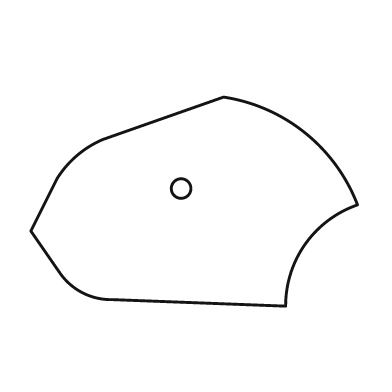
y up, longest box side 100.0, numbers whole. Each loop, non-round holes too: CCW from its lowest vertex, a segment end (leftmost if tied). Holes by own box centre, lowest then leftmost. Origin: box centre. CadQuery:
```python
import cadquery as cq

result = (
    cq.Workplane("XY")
    .moveTo(28.0, -32.0)
    .threePointArc((34.0, -13.0), (50.0, -1.0))
    .threePointArc((34.0, 21.0), (9.0, 32.0))
    .lineTo(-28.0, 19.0)
    .threePointArc((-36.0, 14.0), (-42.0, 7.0))
    .lineTo(-50.0, -9.0)
    .lineTo(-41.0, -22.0)
    .threePointArc((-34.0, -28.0), (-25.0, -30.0))
    .close()
    .moveTo(-4.0, 4.0)
    .circle(3.0)
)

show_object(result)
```